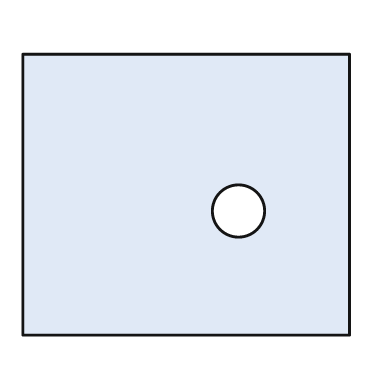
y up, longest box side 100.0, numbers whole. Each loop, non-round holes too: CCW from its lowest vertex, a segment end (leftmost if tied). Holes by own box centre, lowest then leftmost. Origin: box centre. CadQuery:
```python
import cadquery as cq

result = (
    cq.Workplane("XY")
    .moveTo(-50.0, -43.0)
    .lineTo(50.0, -43.0)
    .lineTo(50.0, 43.0)
    .lineTo(-50.0, 43.0)
    .close()
    .moveTo(16.0, -5.0)
    .circle(8.0)
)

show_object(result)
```